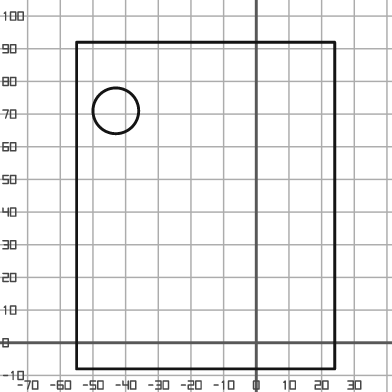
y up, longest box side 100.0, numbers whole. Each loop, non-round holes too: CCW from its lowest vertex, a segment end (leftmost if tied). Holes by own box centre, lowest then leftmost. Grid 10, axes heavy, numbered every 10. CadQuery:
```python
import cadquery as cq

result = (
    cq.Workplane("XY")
    .moveTo(-55.0, -8.0)
    .lineTo(24.0, -8.0)
    .lineTo(24.0, 92.0)
    .lineTo(-55.0, 92.0)
    .close()
    .moveTo(-43.0, 71.0)
    .circle(7.0)
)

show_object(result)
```